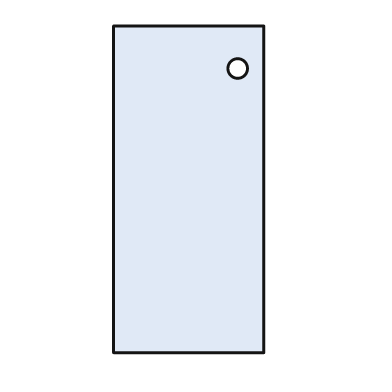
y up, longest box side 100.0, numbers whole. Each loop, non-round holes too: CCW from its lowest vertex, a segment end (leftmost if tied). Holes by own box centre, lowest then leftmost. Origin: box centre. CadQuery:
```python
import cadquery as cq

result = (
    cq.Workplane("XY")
    .moveTo(-23.0, -50.0)
    .lineTo(23.0, -50.0)
    .lineTo(23.0, 50.0)
    .lineTo(-23.0, 50.0)
    .close()
    .moveTo(15.0, 37.0)
    .circle(3.0)
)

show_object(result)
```